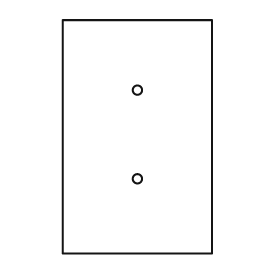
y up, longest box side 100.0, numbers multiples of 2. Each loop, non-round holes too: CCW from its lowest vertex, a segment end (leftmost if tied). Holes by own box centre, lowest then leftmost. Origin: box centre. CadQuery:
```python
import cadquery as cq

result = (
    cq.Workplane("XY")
    .moveTo(-32.0, -50.0)
    .lineTo(32.0, -50.0)
    .lineTo(32.0, 50.0)
    .lineTo(-32.0, 50.0)
    .close()
    .moveTo(0.0, -18.0)
    .circle(2.0)
    .moveTo(0.0, 20.0)
    .circle(2.0)
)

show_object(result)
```